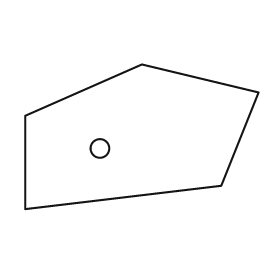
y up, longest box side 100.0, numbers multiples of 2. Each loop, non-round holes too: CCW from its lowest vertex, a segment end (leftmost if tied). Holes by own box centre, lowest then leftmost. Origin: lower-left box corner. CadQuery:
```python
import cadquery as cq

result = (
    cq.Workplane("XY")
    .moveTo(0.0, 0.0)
    .lineTo(84.0, 10.0)
    .lineTo(100.0, 50.0)
    .lineTo(50.0, 62.0)
    .lineTo(0.0, 40.0)
    .close()
    .moveTo(32.0, 26.0)
    .circle(4.0)
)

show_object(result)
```